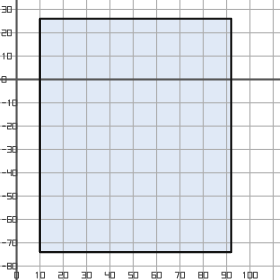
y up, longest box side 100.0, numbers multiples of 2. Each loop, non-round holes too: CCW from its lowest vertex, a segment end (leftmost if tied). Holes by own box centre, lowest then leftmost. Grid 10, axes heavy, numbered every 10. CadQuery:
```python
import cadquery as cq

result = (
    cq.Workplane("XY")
    .moveTo(10.0, -74.0)
    .lineTo(92.0, -74.0)
    .lineTo(92.0, 26.0)
    .lineTo(10.0, 26.0)
    .close()
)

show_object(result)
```